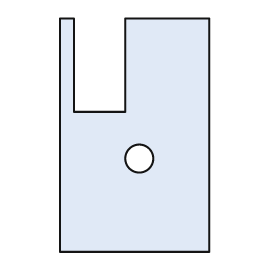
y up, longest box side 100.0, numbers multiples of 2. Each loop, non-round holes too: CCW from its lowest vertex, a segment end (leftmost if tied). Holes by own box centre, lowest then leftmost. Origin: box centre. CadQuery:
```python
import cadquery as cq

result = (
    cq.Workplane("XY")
    .moveTo(-32.0, -50.0)
    .lineTo(32.0, -50.0)
    .lineTo(32.0, 50.0)
    .lineTo(-4.0, 50.0)
    .lineTo(-4.0, 10.0)
    .lineTo(-26.0, 10.0)
    .lineTo(-26.0, 50.0)
    .lineTo(-32.0, 50.0)
    .close()
    .moveTo(2.0, -10.0)
    .circle(6.0)
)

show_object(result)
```